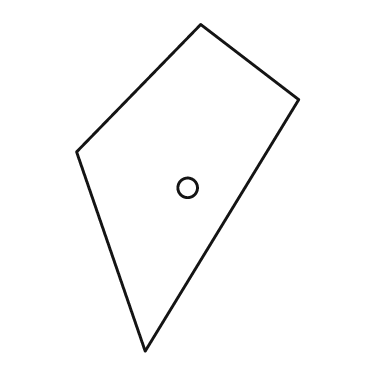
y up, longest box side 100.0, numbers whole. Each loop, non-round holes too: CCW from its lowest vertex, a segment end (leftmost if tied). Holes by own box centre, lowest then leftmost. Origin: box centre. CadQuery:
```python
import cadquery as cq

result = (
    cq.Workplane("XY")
    .moveTo(-13.0, -50.0)
    .lineTo(34.0, 27.0)
    .lineTo(4.0, 50.0)
    .lineTo(-34.0, 11.0)
    .close()
    .moveTo(0.0, 0.0)
    .circle(3.0)
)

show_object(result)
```